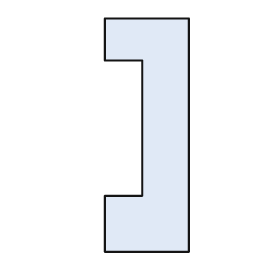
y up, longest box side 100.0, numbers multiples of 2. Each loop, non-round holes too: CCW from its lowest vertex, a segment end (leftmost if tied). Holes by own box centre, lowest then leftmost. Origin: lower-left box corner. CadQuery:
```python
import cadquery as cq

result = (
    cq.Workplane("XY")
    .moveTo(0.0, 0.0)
    .lineTo(36.0, 0.0)
    .lineTo(36.0, 100.0)
    .lineTo(0.0, 100.0)
    .lineTo(0.0, 82.0)
    .lineTo(16.0, 82.0)
    .lineTo(16.0, 24.0)
    .lineTo(0.0, 24.0)
    .close()
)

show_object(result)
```